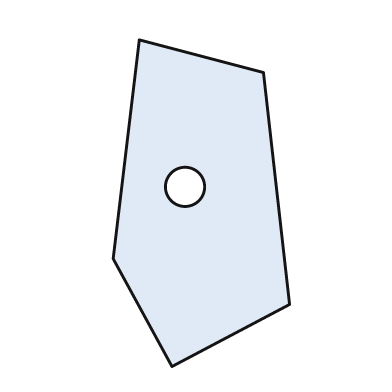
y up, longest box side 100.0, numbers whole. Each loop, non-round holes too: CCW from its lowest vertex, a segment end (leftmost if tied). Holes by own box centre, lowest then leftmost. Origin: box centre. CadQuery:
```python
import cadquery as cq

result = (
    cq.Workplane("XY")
    .moveTo(-9.0, -50.0)
    .lineTo(27.0, -31.0)
    .lineTo(19.0, 40.0)
    .lineTo(-19.0, 50.0)
    .lineTo(-27.0, -17.0)
    .close()
    .moveTo(-5.0, 5.0)
    .circle(6.0)
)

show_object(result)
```